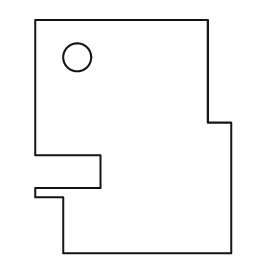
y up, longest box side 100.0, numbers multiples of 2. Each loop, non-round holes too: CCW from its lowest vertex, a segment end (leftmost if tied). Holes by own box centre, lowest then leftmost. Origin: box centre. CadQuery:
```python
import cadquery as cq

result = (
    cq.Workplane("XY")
    .moveTo(-30.0, -50.0)
    .lineTo(42.0, -50.0)
    .lineTo(42.0, 6.0)
    .lineTo(32.0, 6.0)
    .lineTo(32.0, 50.0)
    .lineTo(-42.0, 50.0)
    .lineTo(-42.0, -8.0)
    .lineTo(-14.0, -8.0)
    .lineTo(-14.0, -22.0)
    .lineTo(-42.0, -22.0)
    .lineTo(-42.0, -26.0)
    .lineTo(-30.0, -26.0)
    .close()
    .moveTo(-24.0, 34.0)
    .circle(6.0)
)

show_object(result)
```